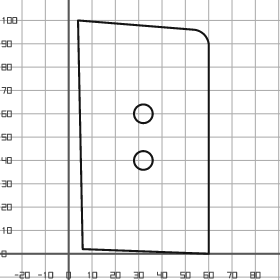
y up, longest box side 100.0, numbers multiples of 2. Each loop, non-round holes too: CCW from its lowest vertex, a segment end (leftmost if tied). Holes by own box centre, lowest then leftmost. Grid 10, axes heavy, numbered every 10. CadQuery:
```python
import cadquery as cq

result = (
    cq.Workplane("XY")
    .moveTo(60.0, 0.0)
    .lineTo(60.0, 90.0)
    .threePointArc((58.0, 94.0), (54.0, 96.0))
    .lineTo(4.0, 100.0)
    .lineTo(6.0, 2.0)
    .close()
    .moveTo(32.0, 40.0)
    .circle(4.0)
    .moveTo(32.0, 60.0)
    .circle(4.0)
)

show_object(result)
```